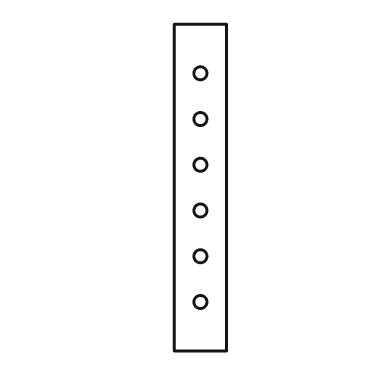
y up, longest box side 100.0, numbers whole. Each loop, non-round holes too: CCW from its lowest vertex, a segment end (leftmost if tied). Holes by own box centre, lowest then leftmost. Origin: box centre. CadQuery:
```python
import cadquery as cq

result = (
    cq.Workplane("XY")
    .moveTo(-8.0, -50.0)
    .lineTo(8.0, -50.0)
    .lineTo(8.0, 50.0)
    .lineTo(-8.0, 50.0)
    .close()
    .moveTo(0.0, -35.0)
    .circle(2.0)
    .moveTo(0.0, -21.0)
    .circle(2.0)
    .moveTo(0.0, -7.0)
    .circle(2.0)
    .moveTo(0.0, 7.0)
    .circle(2.0)
    .moveTo(0.0, 21.0)
    .circle(2.0)
    .moveTo(0.0, 35.0)
    .circle(2.0)
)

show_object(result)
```